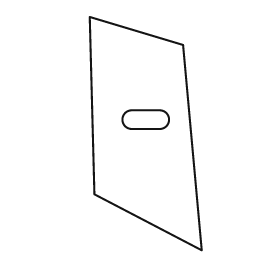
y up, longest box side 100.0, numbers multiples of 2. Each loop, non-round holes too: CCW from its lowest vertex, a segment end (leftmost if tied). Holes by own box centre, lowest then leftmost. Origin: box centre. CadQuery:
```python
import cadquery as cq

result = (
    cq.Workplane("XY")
    .moveTo(24.0, -50.0)
    .lineTo(16.0, 38.0)
    .lineTo(-24.0, 50.0)
    .lineTo(-22.0, -26.0)
    .close()
    .moveTo(-6.0, 2.0)
    .lineTo(6.0, 2.0)
    .threePointArc((10.0, 6.0), (6.0, 10.0))
    .lineTo(-6.0, 10.0)
    .threePointArc((-10.0, 6.0), (-6.0, 2.0))
    .close()
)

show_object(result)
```